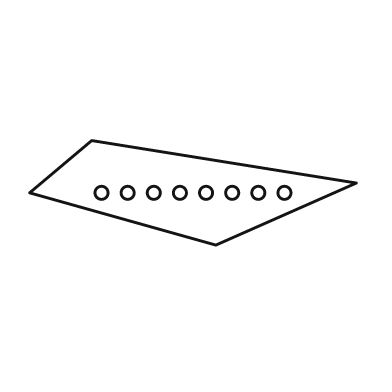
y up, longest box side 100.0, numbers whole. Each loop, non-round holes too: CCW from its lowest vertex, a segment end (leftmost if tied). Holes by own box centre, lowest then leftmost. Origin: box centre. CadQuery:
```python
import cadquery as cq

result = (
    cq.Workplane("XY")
    .moveTo(7.0, -16.0)
    .lineTo(50.0, 3.0)
    .lineTo(-31.0, 16.0)
    .lineTo(-50.0, 0.0)
    .close()
    .moveTo(-28.0, 0.0)
    .circle(2.0)
    .moveTo(-20.0, 0.0)
    .circle(2.0)
    .moveTo(-12.0, 0.0)
    .circle(2.0)
    .moveTo(-4.0, 0.0)
    .circle(2.0)
    .moveTo(4.0, 0.0)
    .circle(2.0)
    .moveTo(12.0, 0.0)
    .circle(2.0)
    .moveTo(20.0, 0.0)
    .circle(2.0)
    .moveTo(28.0, 0.0)
    .circle(2.0)
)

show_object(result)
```